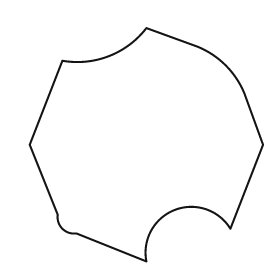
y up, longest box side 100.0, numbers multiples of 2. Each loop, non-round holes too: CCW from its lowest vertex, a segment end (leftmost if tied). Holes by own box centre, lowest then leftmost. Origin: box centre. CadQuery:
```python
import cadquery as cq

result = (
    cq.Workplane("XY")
    .moveTo(0.0, -50.0)
    .threePointArc((12.0, -28.0), (36.0, -36.0))
    .lineTo(50.0, 0.0)
    .lineTo(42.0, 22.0)
    .threePointArc((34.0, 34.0), (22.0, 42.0))
    .lineTo(0.0, 50.0)
    .threePointArc((-16.0, 38.0), (-36.0, 36.0))
    .lineTo(-50.0, 0.0)
    .lineTo(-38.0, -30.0)
    .threePointArc((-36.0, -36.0), (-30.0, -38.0))
    .close()
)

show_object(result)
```